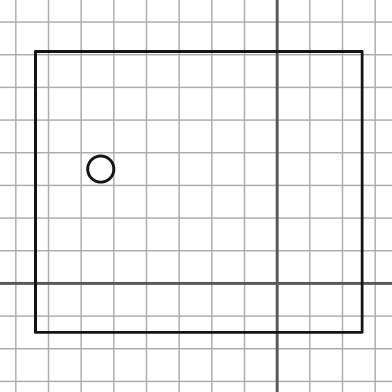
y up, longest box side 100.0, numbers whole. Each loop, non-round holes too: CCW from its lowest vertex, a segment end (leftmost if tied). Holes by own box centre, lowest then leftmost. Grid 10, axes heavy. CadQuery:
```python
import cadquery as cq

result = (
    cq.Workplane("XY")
    .moveTo(-74.0, -15.0)
    .lineTo(26.0, -15.0)
    .lineTo(26.0, 71.0)
    .lineTo(-74.0, 71.0)
    .close()
    .moveTo(-54.0, 35.0)
    .circle(4.0)
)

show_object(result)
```